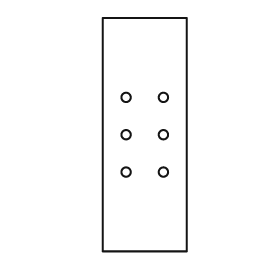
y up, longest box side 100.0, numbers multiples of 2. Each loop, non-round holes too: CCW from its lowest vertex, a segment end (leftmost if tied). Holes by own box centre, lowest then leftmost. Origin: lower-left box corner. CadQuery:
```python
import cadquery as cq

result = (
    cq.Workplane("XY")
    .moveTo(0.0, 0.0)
    .lineTo(36.0, 0.0)
    .lineTo(36.0, 100.0)
    .lineTo(0.0, 100.0)
    .close()
    .moveTo(10.0, 34.0)
    .circle(2.0)
    .moveTo(26.0, 34.0)
    .circle(2.0)
    .moveTo(10.0, 50.0)
    .circle(2.0)
    .moveTo(26.0, 50.0)
    .circle(2.0)
    .moveTo(10.0, 66.0)
    .circle(2.0)
    .moveTo(26.0, 66.0)
    .circle(2.0)
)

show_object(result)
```